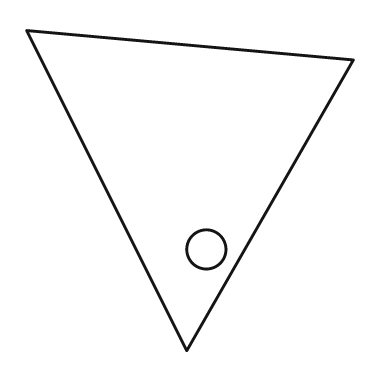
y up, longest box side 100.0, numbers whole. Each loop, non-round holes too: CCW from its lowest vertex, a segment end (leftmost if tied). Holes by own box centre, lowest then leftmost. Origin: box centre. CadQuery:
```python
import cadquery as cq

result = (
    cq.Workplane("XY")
    .moveTo(-1.0, -49.0)
    .lineTo(50.0, 40.0)
    .lineTo(-50.0, 49.0)
    .close()
    .moveTo(5.0, -18.0)
    .circle(6.0)
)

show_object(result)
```